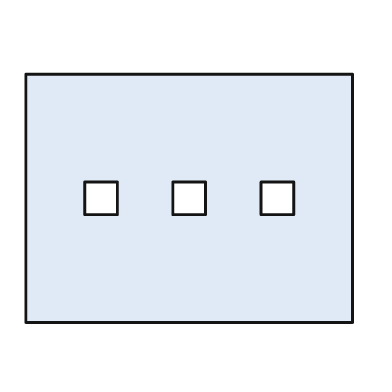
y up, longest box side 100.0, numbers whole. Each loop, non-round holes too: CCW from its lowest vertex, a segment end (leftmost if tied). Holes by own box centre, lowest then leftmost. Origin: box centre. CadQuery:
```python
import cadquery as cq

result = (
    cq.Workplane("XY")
    .moveTo(-50.0, -38.0)
    .lineTo(50.0, -38.0)
    .lineTo(50.0, 38.0)
    .lineTo(-50.0, 38.0)
    .close()
    .moveTo(-32.0, -5.0)
    .lineTo(-22.0, -5.0)
    .lineTo(-22.0, 5.0)
    .lineTo(-32.0, 5.0)
    .close()
    .moveTo(-5.0, -5.0)
    .lineTo(5.0, -5.0)
    .lineTo(5.0, 5.0)
    .lineTo(-5.0, 5.0)
    .close()
    .moveTo(22.0, -5.0)
    .lineTo(32.0, -5.0)
    .lineTo(32.0, 5.0)
    .lineTo(22.0, 5.0)
    .close()
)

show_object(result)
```